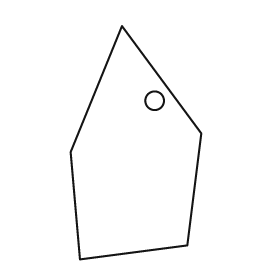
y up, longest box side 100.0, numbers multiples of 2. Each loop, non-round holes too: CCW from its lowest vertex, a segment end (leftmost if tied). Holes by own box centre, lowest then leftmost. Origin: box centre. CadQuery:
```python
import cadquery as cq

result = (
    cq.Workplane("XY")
    .moveTo(-24.0, -50.0)
    .lineTo(22.0, -44.0)
    .lineTo(28.0, 4.0)
    .lineTo(-6.0, 50.0)
    .lineTo(-28.0, -4.0)
    .close()
    .moveTo(8.0, 18.0)
    .circle(4.0)
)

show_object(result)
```